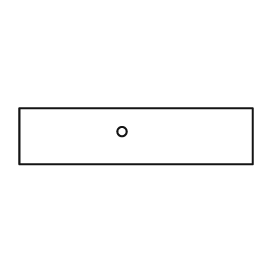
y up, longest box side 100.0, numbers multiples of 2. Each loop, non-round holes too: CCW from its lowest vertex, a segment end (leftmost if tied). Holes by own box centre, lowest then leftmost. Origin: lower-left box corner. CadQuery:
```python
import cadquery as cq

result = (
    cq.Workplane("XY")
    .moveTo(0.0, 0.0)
    .lineTo(100.0, 0.0)
    .lineTo(100.0, 24.0)
    .lineTo(0.0, 24.0)
    .close()
    .moveTo(44.0, 14.0)
    .circle(2.0)
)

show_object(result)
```